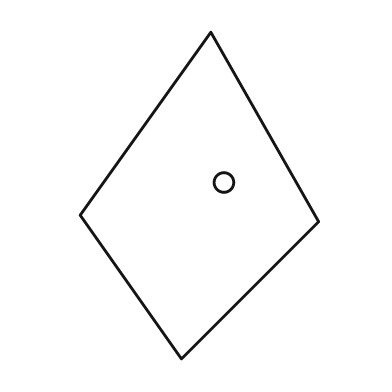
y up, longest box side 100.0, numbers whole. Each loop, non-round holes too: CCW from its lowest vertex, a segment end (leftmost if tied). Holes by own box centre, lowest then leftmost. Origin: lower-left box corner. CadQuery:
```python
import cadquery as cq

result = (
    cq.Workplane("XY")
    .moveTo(31.0, 0.0)
    .lineTo(73.0, 42.0)
    .lineTo(40.0, 100.0)
    .lineTo(0.0, 44.0)
    .close()
    .moveTo(44.0, 54.0)
    .circle(3.0)
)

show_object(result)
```